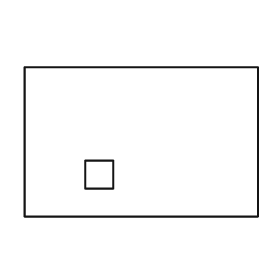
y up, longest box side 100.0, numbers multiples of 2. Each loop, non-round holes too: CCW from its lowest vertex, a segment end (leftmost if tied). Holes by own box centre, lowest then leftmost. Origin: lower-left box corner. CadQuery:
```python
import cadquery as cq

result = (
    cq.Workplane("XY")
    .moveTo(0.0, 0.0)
    .lineTo(100.0, 0.0)
    .lineTo(100.0, 64.0)
    .lineTo(0.0, 64.0)
    .close()
    .moveTo(26.0, 12.0)
    .lineTo(38.0, 12.0)
    .lineTo(38.0, 24.0)
    .lineTo(26.0, 24.0)
    .close()
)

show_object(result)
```